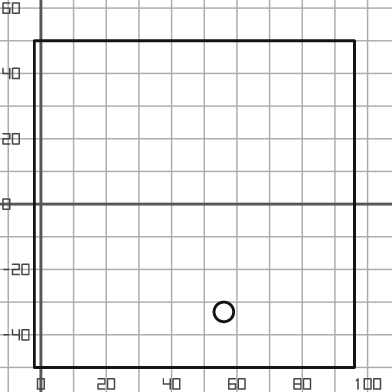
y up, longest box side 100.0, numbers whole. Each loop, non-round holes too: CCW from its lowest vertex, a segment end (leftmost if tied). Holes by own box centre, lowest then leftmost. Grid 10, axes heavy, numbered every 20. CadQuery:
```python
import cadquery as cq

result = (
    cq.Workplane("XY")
    .moveTo(-2.0, -50.0)
    .lineTo(96.0, -50.0)
    .lineTo(96.0, 50.0)
    .lineTo(-2.0, 50.0)
    .close()
    .moveTo(56.0, -33.0)
    .circle(3.0)
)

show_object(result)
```